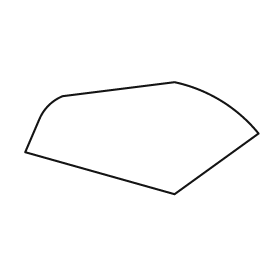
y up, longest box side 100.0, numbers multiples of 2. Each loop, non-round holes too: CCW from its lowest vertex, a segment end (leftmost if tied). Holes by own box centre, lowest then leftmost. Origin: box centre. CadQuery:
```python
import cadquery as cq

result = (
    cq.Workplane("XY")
    .moveTo(14.0, -24.0)
    .lineTo(50.0, 2.0)
    .threePointArc((34.0, 16.0), (14.0, 24.0))
    .lineTo(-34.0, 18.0)
    .threePointArc((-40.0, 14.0), (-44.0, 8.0))
    .lineTo(-50.0, -6.0)
    .close()
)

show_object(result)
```